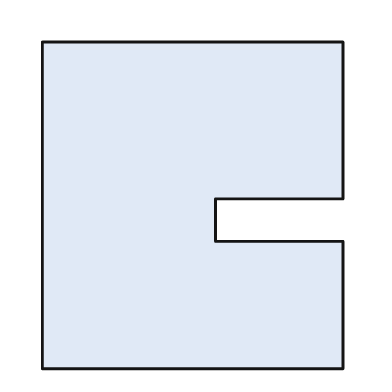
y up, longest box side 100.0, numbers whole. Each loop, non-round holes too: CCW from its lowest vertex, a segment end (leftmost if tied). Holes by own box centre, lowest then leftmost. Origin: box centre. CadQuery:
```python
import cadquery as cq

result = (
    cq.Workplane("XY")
    .moveTo(-46.0, -50.0)
    .lineTo(46.0, -50.0)
    .lineTo(46.0, -11.0)
    .lineTo(7.0, -11.0)
    .lineTo(7.0, 2.0)
    .lineTo(46.0, 2.0)
    .lineTo(46.0, 50.0)
    .lineTo(-46.0, 50.0)
    .close()
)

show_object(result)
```